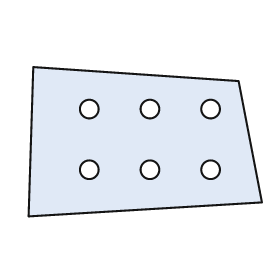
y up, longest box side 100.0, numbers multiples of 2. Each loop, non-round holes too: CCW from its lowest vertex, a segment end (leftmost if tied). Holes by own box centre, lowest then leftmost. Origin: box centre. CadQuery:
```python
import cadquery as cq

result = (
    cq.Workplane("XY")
    .moveTo(-50.0, -32.0)
    .lineTo(50.0, -26.0)
    .lineTo(40.0, 26.0)
    .lineTo(-48.0, 32.0)
    .close()
    .moveTo(-24.0, -12.0)
    .circle(4.0)
    .moveTo(2.0, -12.0)
    .circle(4.0)
    .moveTo(28.0, -12.0)
    .circle(4.0)
    .moveTo(-24.0, 14.0)
    .circle(4.0)
    .moveTo(2.0, 14.0)
    .circle(4.0)
    .moveTo(28.0, 14.0)
    .circle(4.0)
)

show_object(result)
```